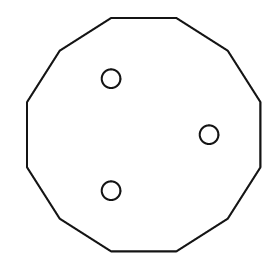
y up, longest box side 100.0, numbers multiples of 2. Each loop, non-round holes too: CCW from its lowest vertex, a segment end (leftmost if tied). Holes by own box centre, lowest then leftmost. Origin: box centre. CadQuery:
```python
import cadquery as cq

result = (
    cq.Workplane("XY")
    .moveTo(-14.0, -50.0)
    .lineTo(14.0, -50.0)
    .lineTo(36.0, -36.0)
    .lineTo(50.0, -14.0)
    .lineTo(50.0, 14.0)
    .lineTo(36.0, 36.0)
    .lineTo(14.0, 50.0)
    .lineTo(-14.0, 50.0)
    .lineTo(-36.0, 36.0)
    .lineTo(-50.0, 14.0)
    .lineTo(-50.0, -14.0)
    .lineTo(-36.0, -36.0)
    .close()
    .moveTo(-14.0, -24.0)
    .circle(4.0)
    .moveTo(28.0, 0.0)
    .circle(4.0)
    .moveTo(-14.0, 24.0)
    .circle(4.0)
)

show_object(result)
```